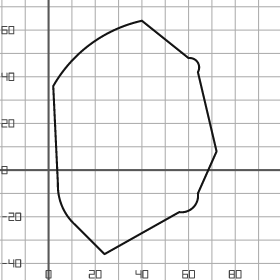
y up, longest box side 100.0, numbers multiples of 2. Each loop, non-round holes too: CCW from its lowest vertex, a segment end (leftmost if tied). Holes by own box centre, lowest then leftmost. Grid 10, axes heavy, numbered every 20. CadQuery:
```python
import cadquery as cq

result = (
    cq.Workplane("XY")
    .moveTo(24.0, -36.0)
    .lineTo(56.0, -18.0)
    .threePointArc((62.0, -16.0), (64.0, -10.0))
    .lineTo(72.0, 8.0)
    .lineTo(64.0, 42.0)
    .threePointArc((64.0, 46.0), (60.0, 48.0))
    .lineTo(40.0, 64.0)
    .threePointArc((18.0, 54.0), (2.0, 36.0))
    .lineTo(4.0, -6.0)
    .threePointArc((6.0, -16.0), (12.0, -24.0))
    .close()
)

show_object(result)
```